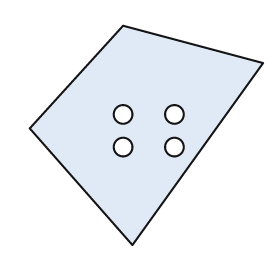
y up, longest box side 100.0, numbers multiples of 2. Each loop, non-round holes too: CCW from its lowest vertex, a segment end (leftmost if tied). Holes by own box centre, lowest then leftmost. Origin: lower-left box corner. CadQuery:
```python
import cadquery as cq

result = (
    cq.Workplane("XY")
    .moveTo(44.0, 0.0)
    .lineTo(100.0, 78.0)
    .lineTo(40.0, 94.0)
    .lineTo(0.0, 50.0)
    .close()
    .moveTo(40.0, 42.0)
    .circle(4.0)
    .moveTo(62.0, 42.0)
    .circle(4.0)
    .moveTo(40.0, 56.0)
    .circle(4.0)
    .moveTo(62.0, 56.0)
    .circle(4.0)
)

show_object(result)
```